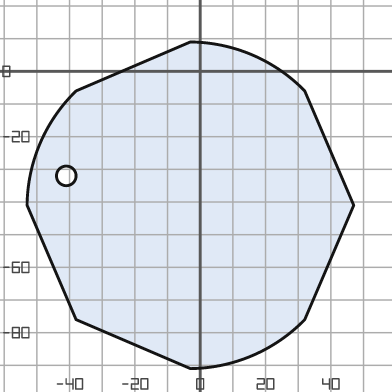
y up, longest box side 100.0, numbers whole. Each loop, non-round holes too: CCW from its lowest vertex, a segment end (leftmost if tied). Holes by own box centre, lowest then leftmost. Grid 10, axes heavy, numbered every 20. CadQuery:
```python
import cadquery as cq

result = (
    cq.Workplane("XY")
    .moveTo(-3.0, -91.0)
    .threePointArc((16.0, -87.0), (32.0, -76.0))
    .lineTo(47.0, -41.0)
    .lineTo(32.0, -6.0)
    .threePointArc((16.0, 5.0), (-3.0, 9.0))
    .lineTo(-38.0, -6.0)
    .threePointArc((-49.0, -22.0), (-53.0, -41.0))
    .lineTo(-38.0, -76.0)
    .close()
    .moveTo(-41.0, -32.0)
    .circle(3.0)
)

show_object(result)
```